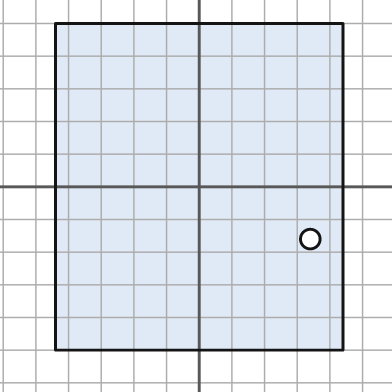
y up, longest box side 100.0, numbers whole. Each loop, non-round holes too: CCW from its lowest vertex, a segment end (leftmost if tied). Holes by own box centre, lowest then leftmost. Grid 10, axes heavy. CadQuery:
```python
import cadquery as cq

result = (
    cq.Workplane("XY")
    .moveTo(-44.0, -50.0)
    .lineTo(44.0, -50.0)
    .lineTo(44.0, 50.0)
    .lineTo(-44.0, 50.0)
    .close()
    .moveTo(34.0, -16.0)
    .circle(3.0)
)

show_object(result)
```